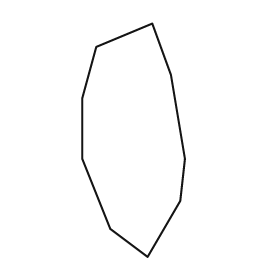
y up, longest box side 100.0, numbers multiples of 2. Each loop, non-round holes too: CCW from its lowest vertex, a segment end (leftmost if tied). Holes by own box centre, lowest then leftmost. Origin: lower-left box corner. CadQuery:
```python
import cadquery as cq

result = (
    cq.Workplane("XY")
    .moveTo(28.0, 0.0)
    .lineTo(42.0, 24.0)
    .lineTo(44.0, 42.0)
    .lineTo(38.0, 78.0)
    .lineTo(30.0, 100.0)
    .lineTo(6.0, 90.0)
    .lineTo(0.0, 68.0)
    .lineTo(0.0, 42.0)
    .lineTo(12.0, 12.0)
    .close()
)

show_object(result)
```